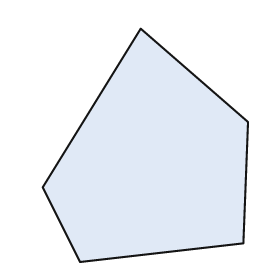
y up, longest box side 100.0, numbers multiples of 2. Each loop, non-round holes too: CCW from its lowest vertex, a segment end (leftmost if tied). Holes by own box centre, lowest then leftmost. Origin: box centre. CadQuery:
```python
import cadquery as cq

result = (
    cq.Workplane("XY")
    .moveTo(-28.0, -50.0)
    .lineTo(42.0, -42.0)
    .lineTo(44.0, 10.0)
    .lineTo(-2.0, 50.0)
    .lineTo(-44.0, -18.0)
    .close()
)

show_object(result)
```